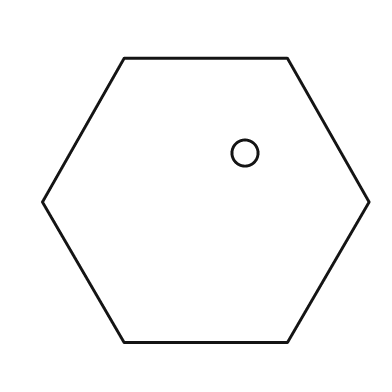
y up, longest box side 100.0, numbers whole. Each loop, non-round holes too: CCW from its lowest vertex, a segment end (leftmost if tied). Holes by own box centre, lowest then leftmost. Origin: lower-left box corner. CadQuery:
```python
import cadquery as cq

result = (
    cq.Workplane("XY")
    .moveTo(25.0, 0.0)
    .lineTo(75.0, 0.0)
    .lineTo(100.0, 43.0)
    .lineTo(75.0, 87.0)
    .lineTo(25.0, 87.0)
    .lineTo(0.0, 43.0)
    .close()
    .moveTo(62.0, 58.0)
    .circle(4.0)
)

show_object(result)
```